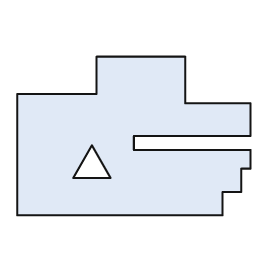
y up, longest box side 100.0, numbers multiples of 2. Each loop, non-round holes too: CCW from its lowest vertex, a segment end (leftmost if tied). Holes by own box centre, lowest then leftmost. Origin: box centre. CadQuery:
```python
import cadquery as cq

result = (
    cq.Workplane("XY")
    .moveTo(-50.0, -34.0)
    .lineTo(38.0, -34.0)
    .lineTo(38.0, -24.0)
    .lineTo(46.0, -24.0)
    .lineTo(46.0, -14.0)
    .lineTo(50.0, -14.0)
    .lineTo(50.0, -6.0)
    .lineTo(0.0, -6.0)
    .lineTo(0.0, 0.0)
    .lineTo(50.0, 0.0)
    .lineTo(50.0, 14.0)
    .lineTo(22.0, 14.0)
    .lineTo(22.0, 34.0)
    .lineTo(-16.0, 34.0)
    .lineTo(-16.0, 18.0)
    .lineTo(-50.0, 18.0)
    .close()
    .moveTo(-26.0, -18.0)
    .lineTo(-10.0, -18.0)
    .lineTo(-18.0, -4.0)
    .close()
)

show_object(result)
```